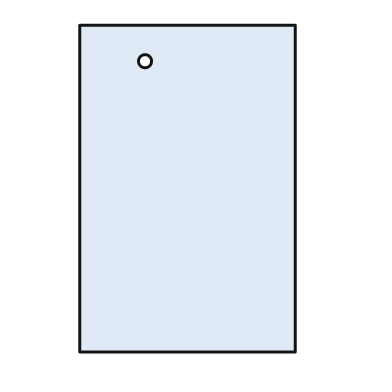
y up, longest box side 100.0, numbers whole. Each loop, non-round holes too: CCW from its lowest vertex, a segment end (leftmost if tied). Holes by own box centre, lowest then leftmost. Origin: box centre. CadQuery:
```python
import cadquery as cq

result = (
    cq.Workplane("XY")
    .moveTo(-33.0, -50.0)
    .lineTo(33.0, -50.0)
    .lineTo(33.0, 50.0)
    .lineTo(-33.0, 50.0)
    .close()
    .moveTo(-13.0, 39.0)
    .circle(2.0)
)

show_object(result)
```